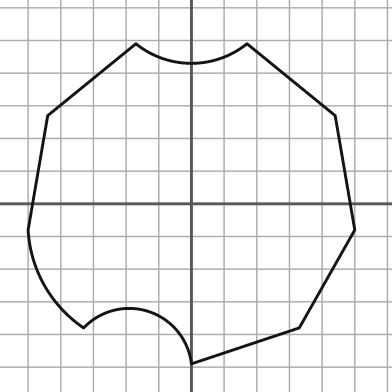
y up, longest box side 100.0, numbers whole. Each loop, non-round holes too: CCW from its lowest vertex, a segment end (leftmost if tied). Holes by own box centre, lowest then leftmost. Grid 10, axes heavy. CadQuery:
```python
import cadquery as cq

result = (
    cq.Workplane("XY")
    .moveTo(0.0, -49.0)
    .lineTo(33.0, -38.0)
    .lineTo(50.0, -8.0)
    .lineTo(44.0, 27.0)
    .lineTo(17.0, 49.0)
    .threePointArc((0.0, 43.0), (-17.0, 49.0))
    .lineTo(-44.0, 27.0)
    .lineTo(-50.0, -8.0)
    .threePointArc((-45.0, -25.0), (-33.0, -38.0))
    .threePointArc((-13.0, -33.0), (0.0, -49.0))
    .close()
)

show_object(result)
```